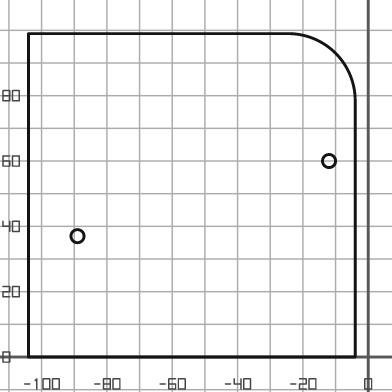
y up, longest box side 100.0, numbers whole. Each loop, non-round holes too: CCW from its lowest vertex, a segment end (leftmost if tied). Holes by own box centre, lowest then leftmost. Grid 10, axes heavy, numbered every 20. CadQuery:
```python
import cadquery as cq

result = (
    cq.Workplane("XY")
    .moveTo(-104.0, 0.0)
    .lineTo(-4.0, 0.0)
    .lineTo(-4.0, 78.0)
    .threePointArc((-10.0, 93.0), (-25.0, 99.0))
    .lineTo(-104.0, 99.0)
    .close()
    .moveTo(-89.0, 37.0)
    .circle(2.0)
    .moveTo(-12.0, 60.0)
    .circle(2.0)
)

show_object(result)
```